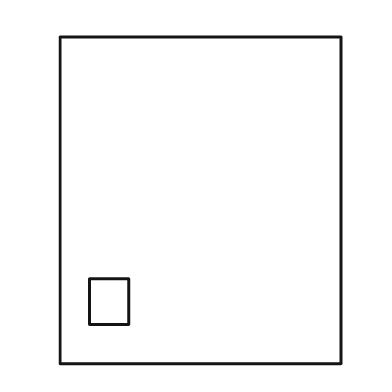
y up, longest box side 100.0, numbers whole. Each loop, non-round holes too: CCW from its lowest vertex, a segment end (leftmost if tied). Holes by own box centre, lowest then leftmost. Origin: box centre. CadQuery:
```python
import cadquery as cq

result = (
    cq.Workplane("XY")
    .moveTo(-43.0, -50.0)
    .lineTo(43.0, -50.0)
    .lineTo(43.0, 50.0)
    .lineTo(-43.0, 50.0)
    .close()
    .moveTo(-34.0, -38.0)
    .lineTo(-22.0, -38.0)
    .lineTo(-22.0, -24.0)
    .lineTo(-34.0, -24.0)
    .close()
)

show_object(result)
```